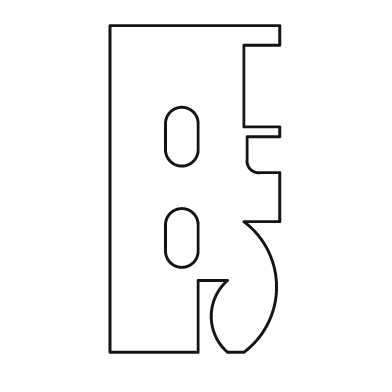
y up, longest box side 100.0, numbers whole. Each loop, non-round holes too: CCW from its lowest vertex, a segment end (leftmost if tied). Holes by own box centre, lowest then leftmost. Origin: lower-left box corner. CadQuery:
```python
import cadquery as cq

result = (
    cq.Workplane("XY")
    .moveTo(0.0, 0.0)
    .lineTo(27.0, 0.0)
    .lineTo(27.0, 22.0)
    .lineTo(36.0, 22.0)
    .threePointArc((31.0, 11.0), (36.0, 0.0))
    .lineTo(41.0, 0.0)
    .threePointArc((51.0, 20.0), (41.0, 40.0))
    .lineTo(52.0, 40.0)
    .lineTo(52.0, 55.0)
    .lineTo(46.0, 55.0)
    .threePointArc((43.0, 56.0), (42.0, 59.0))
    .lineTo(42.0, 66.0)
    .lineTo(52.0, 66.0)
    .lineTo(52.0, 69.0)
    .lineTo(41.0, 69.0)
    .lineTo(41.0, 94.0)
    .lineTo(52.0, 94.0)
    .lineTo(52.0, 100.0)
    .lineTo(0.0, 100.0)
    .close()
    .moveTo(17.0, 31.0)
    .threePointArc((22.0, 26.0), (27.0, 31.0))
    .lineTo(27.0, 39.0)
    .threePointArc((22.0, 44.0), (17.0, 39.0))
    .close()
    .moveTo(17.0, 62.0)
    .threePointArc((22.0, 57.0), (27.0, 62.0))
    .lineTo(27.0, 70.0)
    .threePointArc((22.0, 75.0), (17.0, 70.0))
    .close()
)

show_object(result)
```